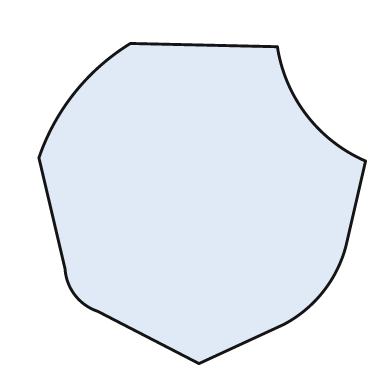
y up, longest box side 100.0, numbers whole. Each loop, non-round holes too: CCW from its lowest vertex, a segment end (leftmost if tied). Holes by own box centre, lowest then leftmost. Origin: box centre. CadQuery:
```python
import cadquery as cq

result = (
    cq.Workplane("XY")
    .moveTo(-1.0, -49.0)
    .lineTo(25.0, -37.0)
    .threePointArc((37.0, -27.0), (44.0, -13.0))
    .lineTo(50.0, 13.0)
    .threePointArc((32.0, 27.0), (23.0, 48.0))
    .lineTo(-22.0, 49.0)
    .threePointArc((-39.0, 34.0), (-50.0, 14.0))
    .lineTo(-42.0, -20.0)
    .threePointArc((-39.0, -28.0), (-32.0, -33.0))
    .close()
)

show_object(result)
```